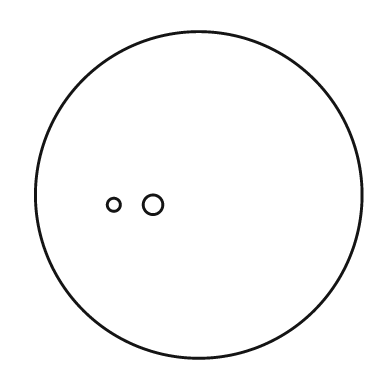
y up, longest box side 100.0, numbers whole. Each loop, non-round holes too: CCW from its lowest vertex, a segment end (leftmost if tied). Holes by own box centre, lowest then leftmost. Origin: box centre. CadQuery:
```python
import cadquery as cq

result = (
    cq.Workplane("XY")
    .moveTo(0.0, 0.0)
    .circle(50.0)
    .moveTo(-26.0, -3.0)
    .circle(2.0)
    .moveTo(-14.0, -3.0)
    .circle(3.0)
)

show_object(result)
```